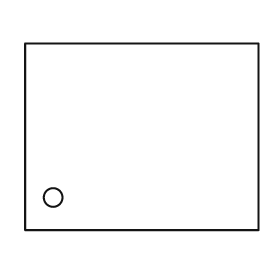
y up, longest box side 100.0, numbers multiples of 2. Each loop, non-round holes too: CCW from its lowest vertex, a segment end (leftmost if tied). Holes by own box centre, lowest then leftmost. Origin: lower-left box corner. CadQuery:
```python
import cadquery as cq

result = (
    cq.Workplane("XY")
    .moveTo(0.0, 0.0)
    .lineTo(100.0, 0.0)
    .lineTo(100.0, 80.0)
    .lineTo(0.0, 80.0)
    .close()
    .moveTo(12.0, 14.0)
    .circle(4.0)
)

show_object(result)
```